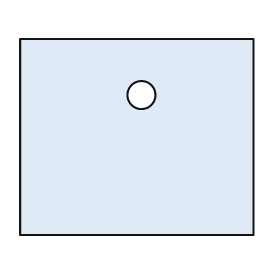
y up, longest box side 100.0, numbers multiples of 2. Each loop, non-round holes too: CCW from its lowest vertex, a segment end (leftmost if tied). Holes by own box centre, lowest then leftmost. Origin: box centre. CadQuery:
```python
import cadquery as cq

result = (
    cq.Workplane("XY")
    .moveTo(-50.0, -42.0)
    .lineTo(50.0, -42.0)
    .lineTo(50.0, 42.0)
    .lineTo(-50.0, 42.0)
    .close()
    .moveTo(2.0, 18.0)
    .circle(6.0)
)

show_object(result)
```